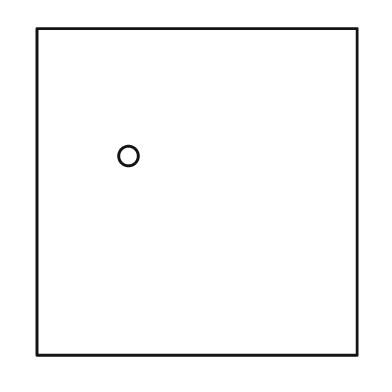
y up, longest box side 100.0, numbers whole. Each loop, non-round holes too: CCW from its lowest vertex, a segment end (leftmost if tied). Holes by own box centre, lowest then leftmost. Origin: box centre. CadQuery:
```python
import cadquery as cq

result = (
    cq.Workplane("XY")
    .moveTo(-49.0, -50.0)
    .lineTo(49.0, -50.0)
    .lineTo(49.0, 50.0)
    .lineTo(-49.0, 50.0)
    .close()
    .moveTo(-21.0, 11.0)
    .circle(3.0)
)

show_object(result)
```